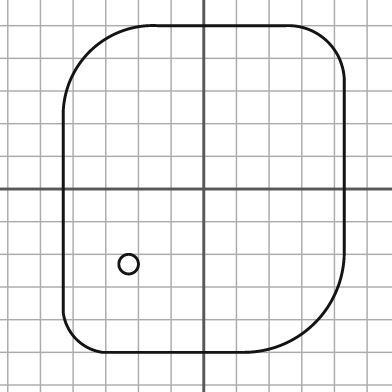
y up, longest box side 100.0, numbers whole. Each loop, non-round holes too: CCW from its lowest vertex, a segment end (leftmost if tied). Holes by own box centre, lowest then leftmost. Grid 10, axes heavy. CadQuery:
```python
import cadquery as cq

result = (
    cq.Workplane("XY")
    .moveTo(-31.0, -50.0)
    .lineTo(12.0, -50.0)
    .threePointArc((34.0, -41.0), (43.0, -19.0))
    .lineTo(43.0, 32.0)
    .threePointArc((38.0, 45.0), (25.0, 50.0))
    .lineTo(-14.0, 50.0)
    .threePointArc((-35.0, 42.0), (-43.0, 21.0))
    .lineTo(-43.0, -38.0)
    .threePointArc((-39.0, -46.0), (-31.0, -50.0))
    .close()
    .moveTo(-23.0, -23.0)
    .circle(3.0)
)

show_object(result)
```